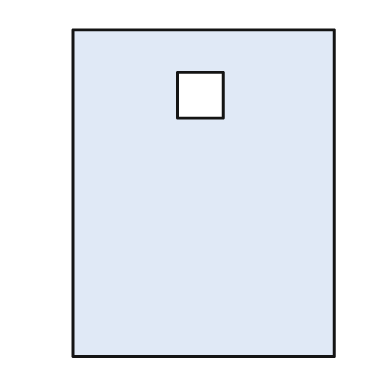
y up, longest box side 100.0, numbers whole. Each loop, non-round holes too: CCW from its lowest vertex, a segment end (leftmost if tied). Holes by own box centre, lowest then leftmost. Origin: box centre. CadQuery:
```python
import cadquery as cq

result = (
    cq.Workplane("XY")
    .moveTo(-40.0, -50.0)
    .lineTo(40.0, -50.0)
    .lineTo(40.0, 50.0)
    .lineTo(-40.0, 50.0)
    .close()
    .moveTo(-8.0, 23.0)
    .lineTo(6.0, 23.0)
    .lineTo(6.0, 37.0)
    .lineTo(-8.0, 37.0)
    .close()
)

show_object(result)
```